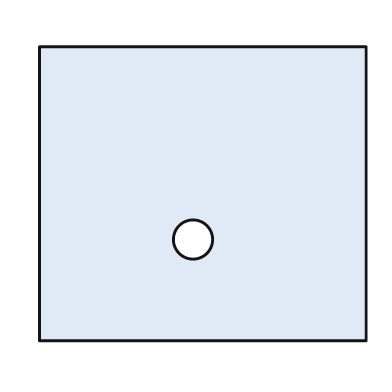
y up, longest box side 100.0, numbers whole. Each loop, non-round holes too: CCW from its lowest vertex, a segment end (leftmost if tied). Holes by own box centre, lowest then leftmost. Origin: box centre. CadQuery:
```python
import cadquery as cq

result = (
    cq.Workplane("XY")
    .moveTo(-50.0, -45.0)
    .lineTo(50.0, -45.0)
    .lineTo(50.0, 45.0)
    .lineTo(-50.0, 45.0)
    .close()
    .moveTo(-3.0, -14.0)
    .circle(6.0)
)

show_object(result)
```